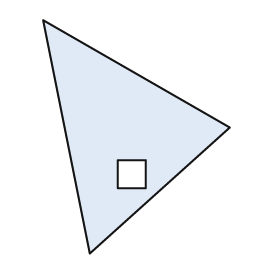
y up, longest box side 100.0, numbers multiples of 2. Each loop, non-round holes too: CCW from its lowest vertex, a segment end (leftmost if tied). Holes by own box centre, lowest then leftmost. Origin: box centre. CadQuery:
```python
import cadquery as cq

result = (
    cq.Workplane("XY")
    .moveTo(-20.0, -50.0)
    .lineTo(40.0, 4.0)
    .lineTo(-40.0, 50.0)
    .close()
    .moveTo(-8.0, -22.0)
    .lineTo(4.0, -22.0)
    .lineTo(4.0, -10.0)
    .lineTo(-8.0, -10.0)
    .close()
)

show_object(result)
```